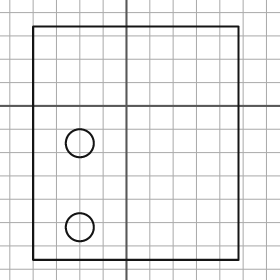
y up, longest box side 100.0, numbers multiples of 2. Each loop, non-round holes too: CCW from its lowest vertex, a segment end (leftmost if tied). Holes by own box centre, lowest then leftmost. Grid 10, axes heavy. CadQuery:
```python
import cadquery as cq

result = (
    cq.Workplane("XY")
    .moveTo(-40.0, -66.0)
    .lineTo(48.0, -66.0)
    .lineTo(48.0, 34.0)
    .lineTo(-40.0, 34.0)
    .close()
    .moveTo(-20.0, -52.0)
    .circle(6.0)
    .moveTo(-20.0, -16.0)
    .circle(6.0)
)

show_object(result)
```